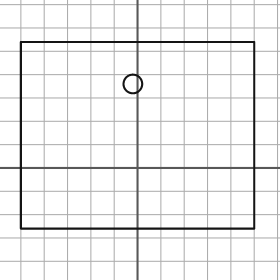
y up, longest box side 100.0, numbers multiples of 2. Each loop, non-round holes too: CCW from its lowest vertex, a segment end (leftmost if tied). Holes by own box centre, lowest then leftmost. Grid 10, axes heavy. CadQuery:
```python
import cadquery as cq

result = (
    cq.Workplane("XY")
    .moveTo(-50.0, -26.0)
    .lineTo(50.0, -26.0)
    .lineTo(50.0, 54.0)
    .lineTo(-50.0, 54.0)
    .close()
    .moveTo(-2.0, 36.0)
    .circle(4.0)
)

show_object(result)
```